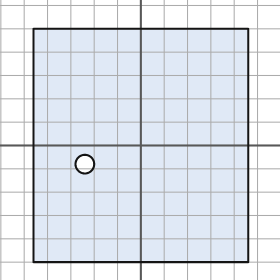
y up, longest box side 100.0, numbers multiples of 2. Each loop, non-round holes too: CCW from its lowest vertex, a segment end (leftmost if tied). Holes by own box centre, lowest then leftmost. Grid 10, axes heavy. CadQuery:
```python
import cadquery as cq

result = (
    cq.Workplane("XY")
    .moveTo(-46.0, -50.0)
    .lineTo(46.0, -50.0)
    .lineTo(46.0, 50.0)
    .lineTo(-46.0, 50.0)
    .close()
    .moveTo(-24.0, -8.0)
    .circle(4.0)
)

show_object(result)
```